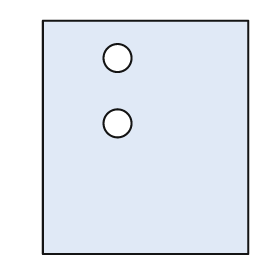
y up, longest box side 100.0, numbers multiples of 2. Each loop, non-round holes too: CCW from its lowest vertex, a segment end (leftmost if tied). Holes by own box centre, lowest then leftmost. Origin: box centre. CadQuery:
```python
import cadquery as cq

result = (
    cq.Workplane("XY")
    .moveTo(-44.0, -50.0)
    .lineTo(44.0, -50.0)
    .lineTo(44.0, 50.0)
    .lineTo(-44.0, 50.0)
    .close()
    .moveTo(-12.0, 6.0)
    .circle(6.0)
    .moveTo(-12.0, 34.0)
    .circle(6.0)
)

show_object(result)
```